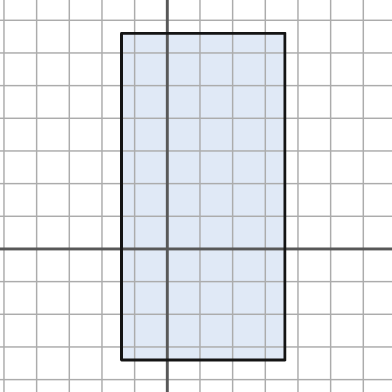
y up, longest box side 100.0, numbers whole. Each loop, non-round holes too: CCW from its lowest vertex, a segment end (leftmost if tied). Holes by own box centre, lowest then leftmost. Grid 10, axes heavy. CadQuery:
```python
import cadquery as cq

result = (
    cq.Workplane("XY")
    .moveTo(-14.0, -34.0)
    .lineTo(36.0, -34.0)
    .lineTo(36.0, 66.0)
    .lineTo(-14.0, 66.0)
    .close()
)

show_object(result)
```